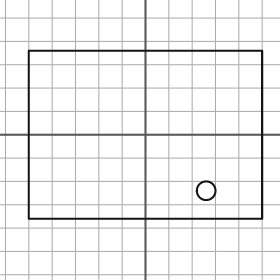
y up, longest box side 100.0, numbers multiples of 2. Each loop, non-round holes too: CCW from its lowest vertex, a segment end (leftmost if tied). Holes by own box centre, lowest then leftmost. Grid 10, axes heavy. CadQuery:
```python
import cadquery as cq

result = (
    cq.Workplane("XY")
    .moveTo(-50.0, -36.0)
    .lineTo(50.0, -36.0)
    .lineTo(50.0, 36.0)
    .lineTo(-50.0, 36.0)
    .close()
    .moveTo(26.0, -24.0)
    .circle(4.0)
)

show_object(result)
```